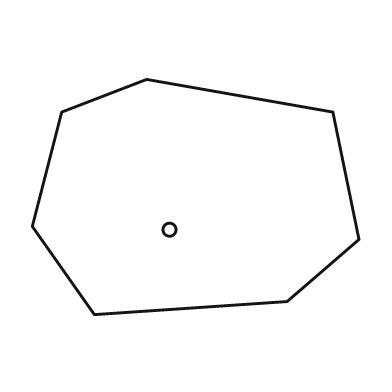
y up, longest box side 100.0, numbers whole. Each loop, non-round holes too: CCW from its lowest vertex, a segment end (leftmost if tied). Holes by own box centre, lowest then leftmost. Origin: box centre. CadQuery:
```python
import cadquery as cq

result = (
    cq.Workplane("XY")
    .moveTo(-31.0, -36.0)
    .lineTo(28.0, -32.0)
    .lineTo(50.0, -13.0)
    .lineTo(42.0, 26.0)
    .lineTo(-15.0, 36.0)
    .lineTo(-41.0, 26.0)
    .lineTo(-50.0, -9.0)
    .close()
    .moveTo(-8.0, -10.0)
    .circle(2.0)
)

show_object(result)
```